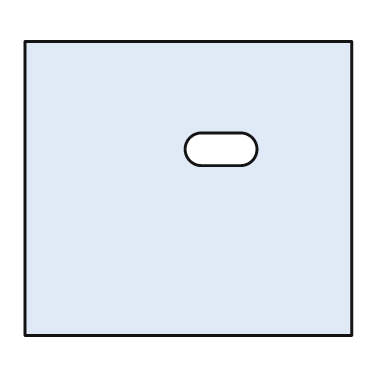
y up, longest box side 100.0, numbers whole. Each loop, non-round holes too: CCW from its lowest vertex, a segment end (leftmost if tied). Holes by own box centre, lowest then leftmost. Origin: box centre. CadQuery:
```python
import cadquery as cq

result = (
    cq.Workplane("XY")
    .moveTo(-50.0, -45.0)
    .lineTo(50.0, -45.0)
    .lineTo(50.0, 45.0)
    .lineTo(-50.0, 45.0)
    .close()
    .moveTo(4.0, 7.0)
    .lineTo(16.0, 7.0)
    .threePointArc((21.0, 12.0), (16.0, 17.0))
    .lineTo(4.0, 17.0)
    .threePointArc((-1.0, 12.0), (4.0, 7.0))
    .close()
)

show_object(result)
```